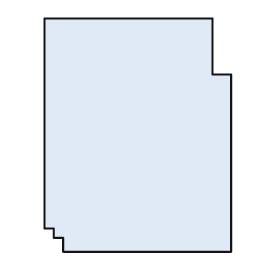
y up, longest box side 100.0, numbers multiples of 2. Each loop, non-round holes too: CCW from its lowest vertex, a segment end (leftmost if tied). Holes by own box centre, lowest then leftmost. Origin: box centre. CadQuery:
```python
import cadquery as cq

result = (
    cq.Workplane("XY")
    .moveTo(-32.0, -50.0)
    .lineTo(40.0, -50.0)
    .lineTo(40.0, 26.0)
    .lineTo(32.0, 26.0)
    .lineTo(32.0, 50.0)
    .lineTo(-40.0, 50.0)
    .lineTo(-40.0, -40.0)
    .lineTo(-36.0, -40.0)
    .lineTo(-36.0, -44.0)
    .lineTo(-32.0, -44.0)
    .close()
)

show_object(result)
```